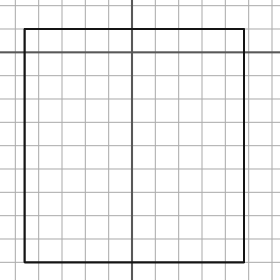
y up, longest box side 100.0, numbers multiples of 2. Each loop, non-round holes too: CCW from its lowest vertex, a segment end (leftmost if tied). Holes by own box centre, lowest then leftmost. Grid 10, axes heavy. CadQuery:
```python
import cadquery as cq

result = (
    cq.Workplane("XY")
    .moveTo(-46.0, -90.0)
    .lineTo(48.0, -90.0)
    .lineTo(48.0, 10.0)
    .lineTo(-46.0, 10.0)
    .close()
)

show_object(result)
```